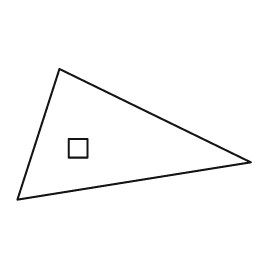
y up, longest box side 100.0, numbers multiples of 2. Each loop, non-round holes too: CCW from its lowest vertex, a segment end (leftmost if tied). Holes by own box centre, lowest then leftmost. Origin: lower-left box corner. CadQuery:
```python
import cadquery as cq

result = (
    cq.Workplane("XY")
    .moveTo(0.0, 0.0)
    .lineTo(100.0, 16.0)
    .lineTo(18.0, 56.0)
    .close()
    .moveTo(22.0, 18.0)
    .lineTo(30.0, 18.0)
    .lineTo(30.0, 26.0)
    .lineTo(22.0, 26.0)
    .close()
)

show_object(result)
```